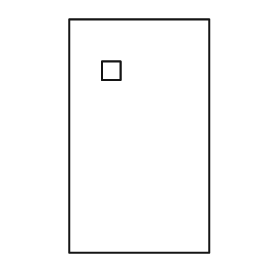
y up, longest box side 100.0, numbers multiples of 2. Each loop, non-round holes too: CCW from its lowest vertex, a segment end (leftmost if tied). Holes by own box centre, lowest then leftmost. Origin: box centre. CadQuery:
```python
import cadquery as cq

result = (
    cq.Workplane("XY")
    .moveTo(-30.0, -50.0)
    .lineTo(30.0, -50.0)
    .lineTo(30.0, 50.0)
    .lineTo(-30.0, 50.0)
    .close()
    .moveTo(-16.0, 24.0)
    .lineTo(-8.0, 24.0)
    .lineTo(-8.0, 32.0)
    .lineTo(-16.0, 32.0)
    .close()
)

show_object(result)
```